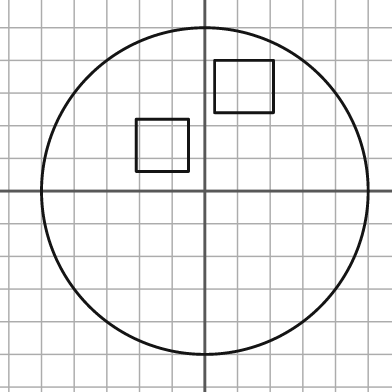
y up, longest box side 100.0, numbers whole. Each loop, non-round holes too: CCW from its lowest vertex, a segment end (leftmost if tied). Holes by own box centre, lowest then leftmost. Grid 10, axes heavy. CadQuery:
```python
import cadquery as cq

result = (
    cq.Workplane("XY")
    .moveTo(0.0, 0.0)
    .circle(50.0)
    .moveTo(-21.0, 6.0)
    .lineTo(-5.0, 6.0)
    .lineTo(-5.0, 22.0)
    .lineTo(-21.0, 22.0)
    .close()
    .moveTo(3.0, 24.0)
    .lineTo(21.0, 24.0)
    .lineTo(21.0, 40.0)
    .lineTo(3.0, 40.0)
    .close()
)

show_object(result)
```